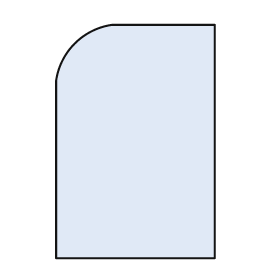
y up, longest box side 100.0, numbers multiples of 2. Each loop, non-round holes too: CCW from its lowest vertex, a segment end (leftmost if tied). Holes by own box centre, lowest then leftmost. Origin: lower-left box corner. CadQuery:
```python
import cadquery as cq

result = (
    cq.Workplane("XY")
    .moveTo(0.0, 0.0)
    .lineTo(68.0, 0.0)
    .lineTo(68.0, 100.0)
    .lineTo(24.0, 100.0)
    .threePointArc((8.0, 92.0), (0.0, 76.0))
    .close()
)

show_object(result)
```